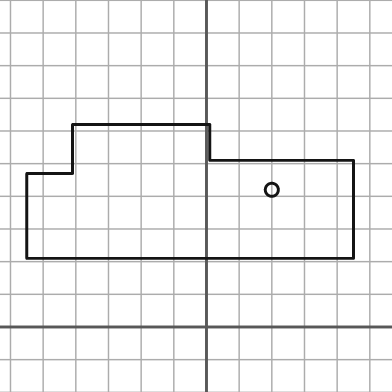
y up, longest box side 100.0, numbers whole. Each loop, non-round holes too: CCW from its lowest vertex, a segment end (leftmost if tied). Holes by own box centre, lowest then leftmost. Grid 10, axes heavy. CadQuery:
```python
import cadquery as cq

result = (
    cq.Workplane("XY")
    .moveTo(-55.0, 21.0)
    .lineTo(45.0, 21.0)
    .lineTo(45.0, 51.0)
    .lineTo(1.0, 51.0)
    .lineTo(1.0, 62.0)
    .lineTo(-41.0, 62.0)
    .lineTo(-41.0, 47.0)
    .lineTo(-55.0, 47.0)
    .close()
    .moveTo(20.0, 42.0)
    .circle(2.0)
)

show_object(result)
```